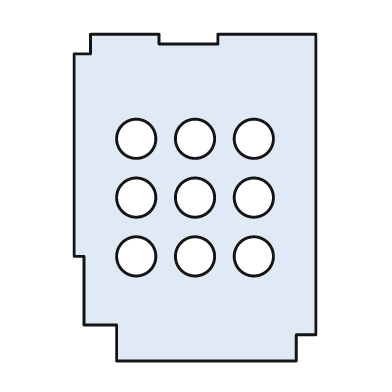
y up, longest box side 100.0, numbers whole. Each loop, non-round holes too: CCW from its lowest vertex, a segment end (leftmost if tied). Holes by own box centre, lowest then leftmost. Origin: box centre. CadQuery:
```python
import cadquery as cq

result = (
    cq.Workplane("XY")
    .moveTo(-24.0, -50.0)
    .lineTo(31.0, -50.0)
    .lineTo(31.0, -42.0)
    .lineTo(37.0, -42.0)
    .lineTo(37.0, 50.0)
    .lineTo(7.0, 50.0)
    .lineTo(7.0, 47.0)
    .lineTo(-11.0, 47.0)
    .lineTo(-11.0, 50.0)
    .lineTo(-32.0, 50.0)
    .lineTo(-32.0, 44.0)
    .lineTo(-37.0, 44.0)
    .lineTo(-37.0, -18.0)
    .lineTo(-34.0, -18.0)
    .lineTo(-34.0, -39.0)
    .lineTo(-24.0, -39.0)
    .close()
    .moveTo(-18.0, -18.0)
    .circle(6.0)
    .moveTo(0.0, -18.0)
    .circle(6.0)
    .moveTo(18.0, -18.0)
    .circle(6.0)
    .moveTo(-18.0, 0.0)
    .circle(6.0)
    .moveTo(0.0, 0.0)
    .circle(6.0)
    .moveTo(18.0, 0.0)
    .circle(6.0)
    .moveTo(-18.0, 18.0)
    .circle(6.0)
    .moveTo(0.0, 18.0)
    .circle(6.0)
    .moveTo(18.0, 18.0)
    .circle(6.0)
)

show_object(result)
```